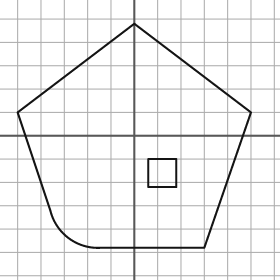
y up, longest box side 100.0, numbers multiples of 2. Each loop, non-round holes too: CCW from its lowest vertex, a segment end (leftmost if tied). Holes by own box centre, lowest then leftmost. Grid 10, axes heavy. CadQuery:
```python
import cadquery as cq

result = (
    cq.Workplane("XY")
    .moveTo(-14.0, -48.0)
    .lineTo(30.0, -48.0)
    .lineTo(50.0, 10.0)
    .lineTo(0.0, 48.0)
    .lineTo(-50.0, 10.0)
    .lineTo(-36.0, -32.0)
    .threePointArc((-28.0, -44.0), (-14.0, -48.0))
    .close()
    .moveTo(6.0, -22.0)
    .lineTo(18.0, -22.0)
    .lineTo(18.0, -10.0)
    .lineTo(6.0, -10.0)
    .close()
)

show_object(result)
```